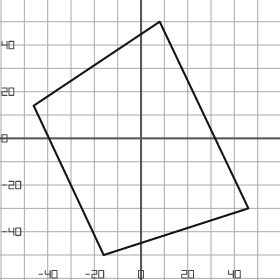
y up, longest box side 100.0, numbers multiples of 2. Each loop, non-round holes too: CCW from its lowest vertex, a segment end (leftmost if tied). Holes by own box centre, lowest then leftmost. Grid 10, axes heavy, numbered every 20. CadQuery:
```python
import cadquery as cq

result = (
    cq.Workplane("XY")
    .moveTo(-16.0, -50.0)
    .lineTo(46.0, -30.0)
    .lineTo(8.0, 50.0)
    .lineTo(-46.0, 14.0)
    .close()
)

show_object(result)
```